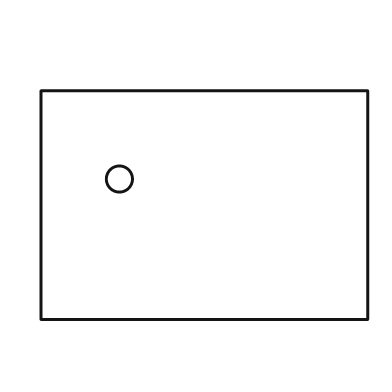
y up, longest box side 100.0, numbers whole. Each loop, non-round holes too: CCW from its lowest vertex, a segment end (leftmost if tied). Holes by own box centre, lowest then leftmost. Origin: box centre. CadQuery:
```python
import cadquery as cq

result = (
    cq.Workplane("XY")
    .moveTo(-50.0, -35.0)
    .lineTo(50.0, -35.0)
    .lineTo(50.0, 35.0)
    .lineTo(-50.0, 35.0)
    .close()
    .moveTo(-26.0, 8.0)
    .circle(4.0)
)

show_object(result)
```